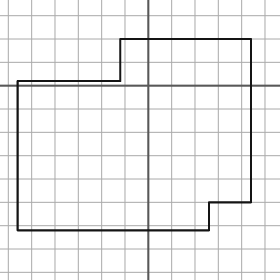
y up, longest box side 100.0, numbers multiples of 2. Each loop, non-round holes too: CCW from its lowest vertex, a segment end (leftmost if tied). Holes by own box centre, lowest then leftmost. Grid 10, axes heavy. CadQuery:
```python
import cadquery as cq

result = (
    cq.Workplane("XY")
    .moveTo(-56.0, -62.0)
    .lineTo(26.0, -62.0)
    .lineTo(26.0, -50.0)
    .lineTo(44.0, -50.0)
    .lineTo(44.0, 20.0)
    .lineTo(-12.0, 20.0)
    .lineTo(-12.0, 2.0)
    .lineTo(-56.0, 2.0)
    .close()
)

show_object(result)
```